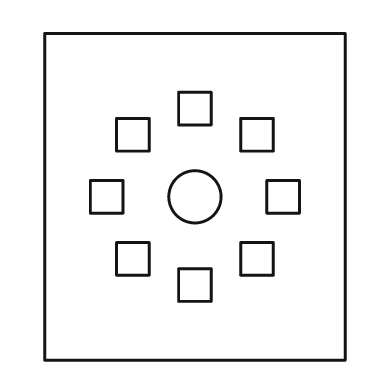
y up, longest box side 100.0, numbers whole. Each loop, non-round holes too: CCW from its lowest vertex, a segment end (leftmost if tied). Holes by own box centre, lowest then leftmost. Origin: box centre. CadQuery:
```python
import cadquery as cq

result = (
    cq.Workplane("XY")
    .moveTo(-46.0, -50.0)
    .lineTo(46.0, -50.0)
    .lineTo(46.0, 50.0)
    .lineTo(-46.0, 50.0)
    .close()
    .moveTo(-5.0, -32.0)
    .lineTo(5.0, -32.0)
    .lineTo(5.0, -22.0)
    .lineTo(-5.0, -22.0)
    .close()
    .moveTo(-24.0, -24.0)
    .lineTo(-14.0, -24.0)
    .lineTo(-14.0, -14.0)
    .lineTo(-24.0, -14.0)
    .close()
    .moveTo(14.0, -24.0)
    .lineTo(24.0, -24.0)
    .lineTo(24.0, -14.0)
    .lineTo(14.0, -14.0)
    .close()
    .moveTo(-32.0, -5.0)
    .lineTo(-22.0, -5.0)
    .lineTo(-22.0, 5.0)
    .lineTo(-32.0, 5.0)
    .close()
    .moveTo(0.0, 0.0)
    .circle(8.0)
    .moveTo(22.0, -5.0)
    .lineTo(32.0, -5.0)
    .lineTo(32.0, 5.0)
    .lineTo(22.0, 5.0)
    .close()
    .moveTo(-24.0, 14.0)
    .lineTo(-14.0, 14.0)
    .lineTo(-14.0, 24.0)
    .lineTo(-24.0, 24.0)
    .close()
    .moveTo(14.0, 14.0)
    .lineTo(24.0, 14.0)
    .lineTo(24.0, 24.0)
    .lineTo(14.0, 24.0)
    .close()
    .moveTo(-5.0, 22.0)
    .lineTo(5.0, 22.0)
    .lineTo(5.0, 32.0)
    .lineTo(-5.0, 32.0)
    .close()
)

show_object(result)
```